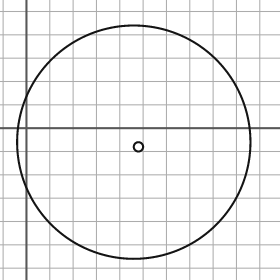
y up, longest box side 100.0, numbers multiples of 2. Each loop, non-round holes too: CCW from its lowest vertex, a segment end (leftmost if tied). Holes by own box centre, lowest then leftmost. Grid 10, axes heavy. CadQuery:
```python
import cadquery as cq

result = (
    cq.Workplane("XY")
    .moveTo(46.0, -6.0)
    .circle(50.0)
    .moveTo(48.0, -8.0)
    .circle(2.0)
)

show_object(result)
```